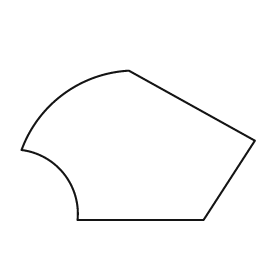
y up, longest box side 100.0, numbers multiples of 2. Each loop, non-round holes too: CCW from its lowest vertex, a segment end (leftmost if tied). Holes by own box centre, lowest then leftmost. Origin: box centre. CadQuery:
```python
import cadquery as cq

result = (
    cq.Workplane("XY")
    .moveTo(-26.0, -32.0)
    .lineTo(28.0, -32.0)
    .lineTo(50.0, 2.0)
    .lineTo(-4.0, 32.0)
    .threePointArc((-32.0, 22.0), (-50.0, -2.0))
    .threePointArc((-32.0, -12.0), (-26.0, -32.0))
    .close()
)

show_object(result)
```